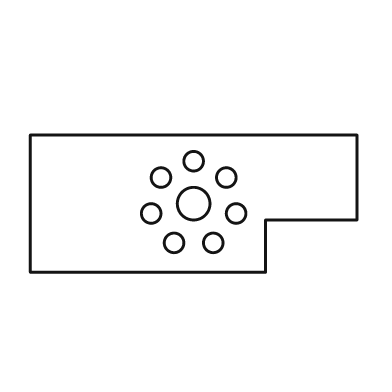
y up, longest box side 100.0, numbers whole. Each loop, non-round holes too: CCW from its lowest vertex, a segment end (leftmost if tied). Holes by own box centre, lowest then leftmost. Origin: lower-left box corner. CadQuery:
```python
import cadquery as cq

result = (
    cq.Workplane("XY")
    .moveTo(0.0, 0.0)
    .lineTo(72.0, 0.0)
    .lineTo(72.0, 16.0)
    .lineTo(100.0, 16.0)
    .lineTo(100.0, 42.0)
    .lineTo(0.0, 42.0)
    .close()
    .moveTo(44.0, 9.0)
    .circle(3.0)
    .moveTo(56.0, 9.0)
    .circle(3.0)
    .moveTo(37.0, 18.0)
    .circle(3.0)
    .moveTo(63.0, 18.0)
    .circle(3.0)
    .moveTo(50.0, 21.0)
    .circle(5.0)
    .moveTo(40.0, 29.0)
    .circle(3.0)
    .moveTo(60.0, 29.0)
    .circle(3.0)
    .moveTo(50.0, 34.0)
    .circle(3.0)
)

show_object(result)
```